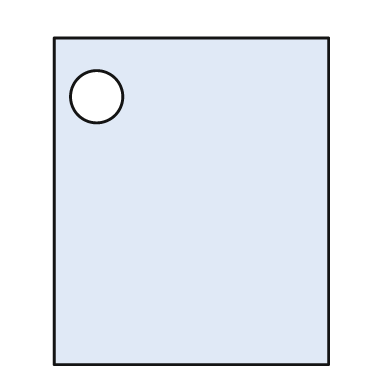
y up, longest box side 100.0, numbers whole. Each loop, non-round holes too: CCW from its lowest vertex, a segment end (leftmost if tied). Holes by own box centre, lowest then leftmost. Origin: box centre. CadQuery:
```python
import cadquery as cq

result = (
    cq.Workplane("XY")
    .moveTo(-42.0, -50.0)
    .lineTo(42.0, -50.0)
    .lineTo(42.0, 50.0)
    .lineTo(-42.0, 50.0)
    .close()
    .moveTo(-29.0, 32.0)
    .circle(8.0)
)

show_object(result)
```